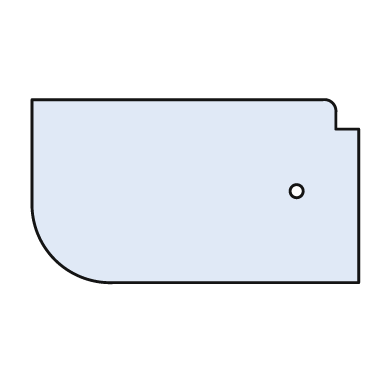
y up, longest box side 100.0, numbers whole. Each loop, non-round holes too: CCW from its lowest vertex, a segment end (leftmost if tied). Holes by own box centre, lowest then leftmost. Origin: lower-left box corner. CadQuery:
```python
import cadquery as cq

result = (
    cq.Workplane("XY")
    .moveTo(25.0, 0.0)
    .lineTo(100.0, 0.0)
    .lineTo(100.0, 47.0)
    .lineTo(93.0, 47.0)
    .lineTo(93.0, 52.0)
    .threePointArc((92.0, 55.0), (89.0, 56.0))
    .lineTo(0.0, 56.0)
    .lineTo(0.0, 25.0)
    .threePointArc((7.0, 7.0), (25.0, 0.0))
    .close()
    .moveTo(81.0, 28.0)
    .circle(2.0)
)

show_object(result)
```